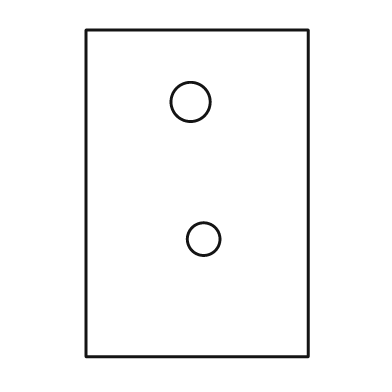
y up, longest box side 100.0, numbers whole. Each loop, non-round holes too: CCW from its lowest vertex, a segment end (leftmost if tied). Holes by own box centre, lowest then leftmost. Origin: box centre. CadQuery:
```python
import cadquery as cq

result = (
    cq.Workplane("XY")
    .moveTo(-34.0, -50.0)
    .lineTo(34.0, -50.0)
    .lineTo(34.0, 50.0)
    .lineTo(-34.0, 50.0)
    .close()
    .moveTo(2.0, -14.0)
    .circle(5.0)
    .moveTo(-2.0, 28.0)
    .circle(6.0)
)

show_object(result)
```